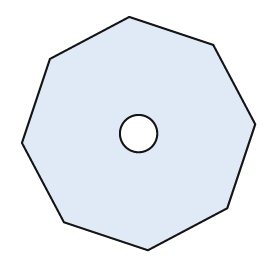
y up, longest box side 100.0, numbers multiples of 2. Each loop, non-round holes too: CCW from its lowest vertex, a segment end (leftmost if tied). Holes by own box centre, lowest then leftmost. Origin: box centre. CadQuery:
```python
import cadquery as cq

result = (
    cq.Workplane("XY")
    .moveTo(4.0, -50.0)
    .lineTo(38.0, -32.0)
    .lineTo(50.0, 4.0)
    .lineTo(32.0, 38.0)
    .lineTo(-4.0, 50.0)
    .lineTo(-38.0, 32.0)
    .lineTo(-50.0, -4.0)
    .lineTo(-32.0, -38.0)
    .close()
    .moveTo(0.0, 0.0)
    .circle(8.0)
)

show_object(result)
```